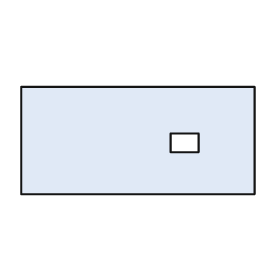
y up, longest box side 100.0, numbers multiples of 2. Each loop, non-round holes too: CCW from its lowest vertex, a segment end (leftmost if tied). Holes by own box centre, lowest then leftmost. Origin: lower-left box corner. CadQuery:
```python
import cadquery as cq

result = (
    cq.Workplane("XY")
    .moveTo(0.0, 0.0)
    .lineTo(100.0, 0.0)
    .lineTo(100.0, 46.0)
    .lineTo(0.0, 46.0)
    .close()
    .moveTo(64.0, 18.0)
    .lineTo(76.0, 18.0)
    .lineTo(76.0, 26.0)
    .lineTo(64.0, 26.0)
    .close()
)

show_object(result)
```